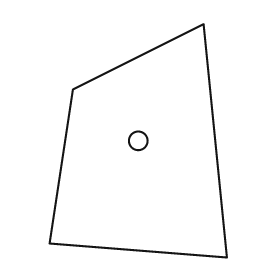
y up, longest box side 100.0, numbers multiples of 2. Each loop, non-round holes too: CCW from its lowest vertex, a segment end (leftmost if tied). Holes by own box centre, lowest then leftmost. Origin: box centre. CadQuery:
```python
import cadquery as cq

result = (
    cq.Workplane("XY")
    .moveTo(38.0, -50.0)
    .lineTo(28.0, 50.0)
    .lineTo(-28.0, 22.0)
    .lineTo(-38.0, -44.0)
    .close()
    .moveTo(0.0, 0.0)
    .circle(4.0)
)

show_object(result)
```